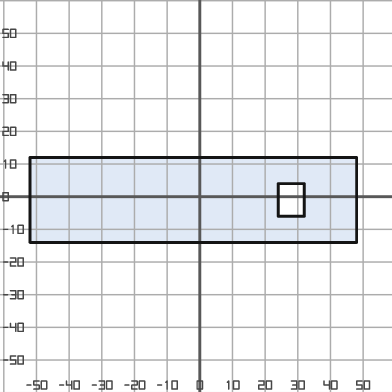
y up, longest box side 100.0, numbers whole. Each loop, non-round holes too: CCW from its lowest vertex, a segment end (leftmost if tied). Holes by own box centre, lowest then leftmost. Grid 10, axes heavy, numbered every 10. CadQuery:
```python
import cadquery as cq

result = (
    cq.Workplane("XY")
    .moveTo(-52.0, -14.0)
    .lineTo(48.0, -14.0)
    .lineTo(48.0, 12.0)
    .lineTo(-52.0, 12.0)
    .close()
    .moveTo(24.0, -6.0)
    .lineTo(32.0, -6.0)
    .lineTo(32.0, 4.0)
    .lineTo(24.0, 4.0)
    .close()
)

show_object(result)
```